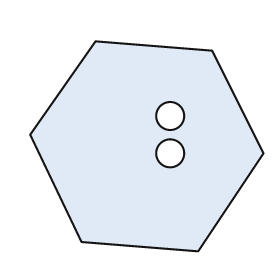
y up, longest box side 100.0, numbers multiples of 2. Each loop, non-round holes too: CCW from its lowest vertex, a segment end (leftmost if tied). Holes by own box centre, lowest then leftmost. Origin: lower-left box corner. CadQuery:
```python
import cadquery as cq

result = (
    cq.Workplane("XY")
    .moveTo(72.0, 0.0)
    .lineTo(100.0, 42.0)
    .lineTo(78.0, 86.0)
    .lineTo(28.0, 90.0)
    .lineTo(0.0, 50.0)
    .lineTo(22.0, 4.0)
    .close()
    .moveTo(60.0, 42.0)
    .circle(6.0)
    .moveTo(60.0, 58.0)
    .circle(6.0)
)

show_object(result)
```